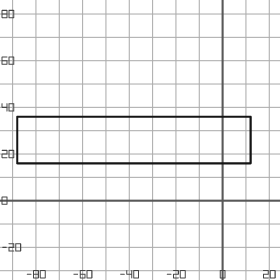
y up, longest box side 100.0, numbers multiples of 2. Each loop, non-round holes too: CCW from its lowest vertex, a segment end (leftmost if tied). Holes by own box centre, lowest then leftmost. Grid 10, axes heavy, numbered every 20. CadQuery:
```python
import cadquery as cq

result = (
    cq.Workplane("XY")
    .moveTo(-88.0, 16.0)
    .lineTo(12.0, 16.0)
    .lineTo(12.0, 36.0)
    .lineTo(-88.0, 36.0)
    .close()
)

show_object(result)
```